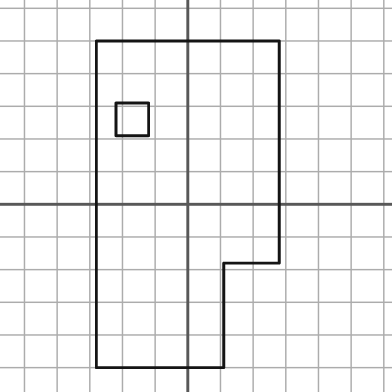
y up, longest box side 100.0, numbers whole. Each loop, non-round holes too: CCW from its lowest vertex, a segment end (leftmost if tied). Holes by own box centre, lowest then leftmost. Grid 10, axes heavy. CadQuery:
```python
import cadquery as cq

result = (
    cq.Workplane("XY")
    .moveTo(-28.0, -50.0)
    .lineTo(11.0, -50.0)
    .lineTo(11.0, -18.0)
    .lineTo(28.0, -18.0)
    .lineTo(28.0, 50.0)
    .lineTo(-28.0, 50.0)
    .close()
    .moveTo(-22.0, 21.0)
    .lineTo(-12.0, 21.0)
    .lineTo(-12.0, 31.0)
    .lineTo(-22.0, 31.0)
    .close()
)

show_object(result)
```